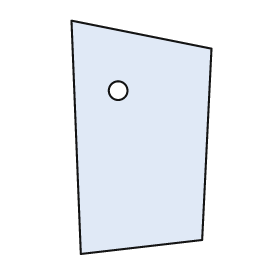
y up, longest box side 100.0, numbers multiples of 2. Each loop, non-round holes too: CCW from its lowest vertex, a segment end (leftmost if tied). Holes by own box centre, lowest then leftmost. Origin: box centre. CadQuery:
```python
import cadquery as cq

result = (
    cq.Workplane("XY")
    .moveTo(-26.0, -50.0)
    .lineTo(26.0, -44.0)
    .lineTo(30.0, 38.0)
    .lineTo(-30.0, 50.0)
    .close()
    .moveTo(-10.0, 20.0)
    .circle(4.0)
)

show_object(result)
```